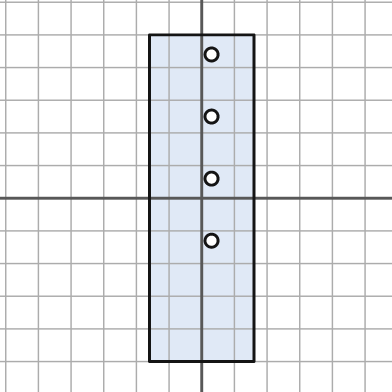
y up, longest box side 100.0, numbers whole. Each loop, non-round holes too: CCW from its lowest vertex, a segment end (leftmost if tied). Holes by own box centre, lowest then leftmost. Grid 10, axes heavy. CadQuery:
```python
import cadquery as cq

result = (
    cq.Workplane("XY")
    .moveTo(-16.0, -50.0)
    .lineTo(16.0, -50.0)
    .lineTo(16.0, 50.0)
    .lineTo(-16.0, 50.0)
    .close()
    .moveTo(3.0, -13.0)
    .circle(2.0)
    .moveTo(3.0, 6.0)
    .circle(2.0)
    .moveTo(3.0, 25.0)
    .circle(2.0)
    .moveTo(3.0, 44.0)
    .circle(2.0)
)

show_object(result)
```